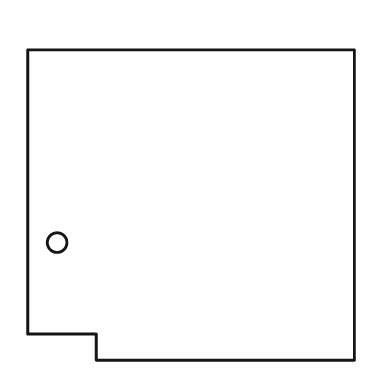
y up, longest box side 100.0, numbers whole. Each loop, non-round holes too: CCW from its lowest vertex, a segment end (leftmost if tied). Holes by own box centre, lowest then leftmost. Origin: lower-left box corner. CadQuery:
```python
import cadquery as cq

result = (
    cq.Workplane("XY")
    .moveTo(21.0, 0.0)
    .lineTo(100.0, 0.0)
    .lineTo(100.0, 95.0)
    .lineTo(0.0, 95.0)
    .lineTo(0.0, 8.0)
    .lineTo(21.0, 8.0)
    .close()
    .moveTo(9.0, 36.0)
    .circle(3.0)
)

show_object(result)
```